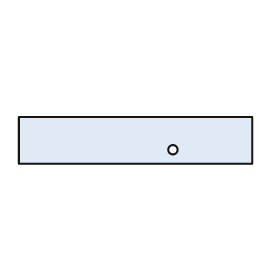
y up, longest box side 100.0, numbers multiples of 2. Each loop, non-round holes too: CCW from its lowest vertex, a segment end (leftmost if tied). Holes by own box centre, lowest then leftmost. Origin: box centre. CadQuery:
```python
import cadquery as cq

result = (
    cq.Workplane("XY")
    .moveTo(-50.0, -10.0)
    .lineTo(50.0, -10.0)
    .lineTo(50.0, 10.0)
    .lineTo(-50.0, 10.0)
    .close()
    .moveTo(16.0, -4.0)
    .circle(2.0)
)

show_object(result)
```